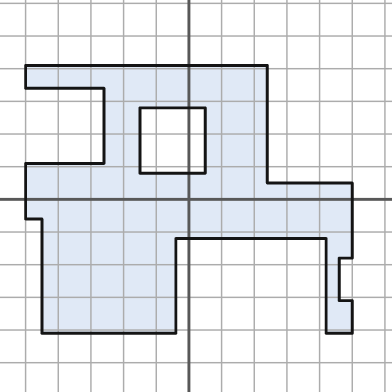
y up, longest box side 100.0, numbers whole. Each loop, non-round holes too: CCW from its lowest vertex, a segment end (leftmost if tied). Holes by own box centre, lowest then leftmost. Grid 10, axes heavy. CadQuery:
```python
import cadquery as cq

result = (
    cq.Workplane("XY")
    .moveTo(-45.0, -41.0)
    .lineTo(-4.0, -41.0)
    .lineTo(-4.0, -12.0)
    .lineTo(42.0, -12.0)
    .lineTo(42.0, -41.0)
    .lineTo(50.0, -41.0)
    .lineTo(50.0, -31.0)
    .lineTo(46.0, -31.0)
    .lineTo(46.0, -18.0)
    .lineTo(50.0, -18.0)
    .lineTo(50.0, 5.0)
    .lineTo(24.0, 5.0)
    .lineTo(24.0, 41.0)
    .lineTo(-50.0, 41.0)
    .lineTo(-50.0, 34.0)
    .lineTo(-26.0, 34.0)
    .lineTo(-26.0, 11.0)
    .lineTo(-50.0, 11.0)
    .lineTo(-50.0, -6.0)
    .lineTo(-45.0, -6.0)
    .close()
    .moveTo(-15.0, 8.0)
    .lineTo(5.0, 8.0)
    .lineTo(5.0, 28.0)
    .lineTo(-15.0, 28.0)
    .close()
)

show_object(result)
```